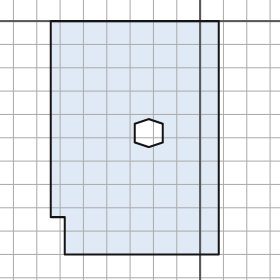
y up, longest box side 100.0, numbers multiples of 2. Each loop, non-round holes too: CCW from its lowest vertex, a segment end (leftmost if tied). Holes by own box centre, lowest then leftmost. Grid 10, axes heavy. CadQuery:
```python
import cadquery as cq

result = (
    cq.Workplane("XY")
    .moveTo(-58.0, -100.0)
    .lineTo(8.0, -100.0)
    .lineTo(8.0, 0.0)
    .lineTo(-64.0, 0.0)
    .lineTo(-64.0, -84.0)
    .lineTo(-58.0, -84.0)
    .close()
    .moveTo(-22.0, -54.0)
    .lineTo(-16.0, -52.0)
    .lineTo(-16.0, -44.0)
    .lineTo(-22.0, -42.0)
    .lineTo(-28.0, -44.0)
    .lineTo(-28.0, -52.0)
    .close()
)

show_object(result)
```